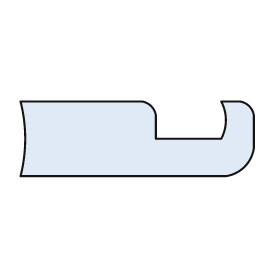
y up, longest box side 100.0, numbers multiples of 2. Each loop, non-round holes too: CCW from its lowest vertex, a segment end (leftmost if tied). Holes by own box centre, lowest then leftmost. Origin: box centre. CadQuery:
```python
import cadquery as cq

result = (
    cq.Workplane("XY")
    .moveTo(-50.0, -16.0)
    .lineTo(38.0, -16.0)
    .threePointArc((46.0, -12.0), (50.0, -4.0))
    .lineTo(50.0, 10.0)
    .threePointArc((48.0, 14.0), (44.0, 16.0))
    .lineTo(36.0, 16.0)
    .threePointArc((38.0, 8.0), (36.0, 0.0))
    .lineTo(8.0, 0.0)
    .lineTo(8.0, 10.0)
    .threePointArc((6.0, 14.0), (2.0, 16.0))
    .lineTo(-50.0, 16.0)
    .threePointArc((-48.0, 0.0), (-50.0, -16.0))
    .close()
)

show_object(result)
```